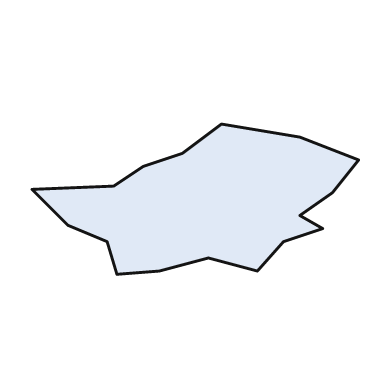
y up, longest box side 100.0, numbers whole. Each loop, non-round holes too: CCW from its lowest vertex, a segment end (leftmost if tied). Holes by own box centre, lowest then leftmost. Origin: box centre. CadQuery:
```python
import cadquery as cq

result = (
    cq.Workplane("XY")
    .moveTo(-24.0, -23.0)
    .lineTo(-11.0, -22.0)
    .lineTo(4.0, -18.0)
    .lineTo(19.0, -22.0)
    .lineTo(27.0, -13.0)
    .lineTo(39.0, -9.0)
    .lineTo(32.0, -5.0)
    .lineTo(42.0, 2.0)
    .lineTo(50.0, 12.0)
    .lineTo(32.0, 19.0)
    .lineTo(8.0, 23.0)
    .lineTo(-4.0, 14.0)
    .lineTo(-16.0, 10.0)
    .lineTo(-25.0, 4.0)
    .lineTo(-50.0, 3.0)
    .lineTo(-39.0, -8.0)
    .lineTo(-27.0, -13.0)
    .close()
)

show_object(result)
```